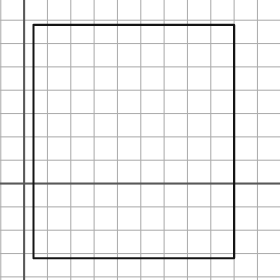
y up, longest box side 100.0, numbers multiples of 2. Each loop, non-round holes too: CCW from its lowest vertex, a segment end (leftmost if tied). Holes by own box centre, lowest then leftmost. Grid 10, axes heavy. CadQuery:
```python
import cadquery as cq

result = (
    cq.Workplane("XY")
    .moveTo(4.0, -32.0)
    .lineTo(90.0, -32.0)
    .lineTo(90.0, 68.0)
    .lineTo(4.0, 68.0)
    .close()
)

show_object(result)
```